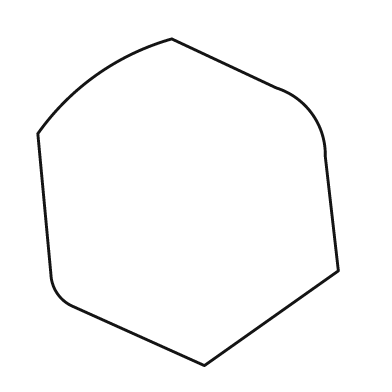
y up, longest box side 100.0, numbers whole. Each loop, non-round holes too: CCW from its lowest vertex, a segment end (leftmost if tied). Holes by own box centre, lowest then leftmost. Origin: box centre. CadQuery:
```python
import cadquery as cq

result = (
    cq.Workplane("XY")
    .moveTo(5.0, -50.0)
    .lineTo(46.0, -21.0)
    .lineTo(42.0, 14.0)
    .threePointArc((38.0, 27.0), (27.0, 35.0))
    .lineTo(-5.0, 50.0)
    .threePointArc((-28.0, 39.0), (-46.0, 21.0))
    .lineTo(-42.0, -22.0)
    .threePointArc((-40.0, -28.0), (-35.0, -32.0))
    .close()
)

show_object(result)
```